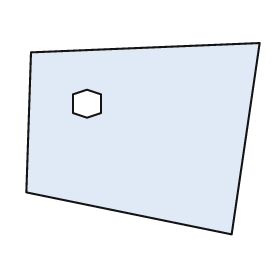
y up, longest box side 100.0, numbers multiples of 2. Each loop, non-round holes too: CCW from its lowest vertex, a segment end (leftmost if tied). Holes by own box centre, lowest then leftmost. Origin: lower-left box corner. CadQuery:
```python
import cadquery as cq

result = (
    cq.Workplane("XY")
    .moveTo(88.0, 0.0)
    .lineTo(100.0, 82.0)
    .lineTo(2.0, 78.0)
    .lineTo(0.0, 18.0)
    .close()
    .moveTo(26.0, 50.0)
    .lineTo(32.0, 52.0)
    .lineTo(32.0, 60.0)
    .lineTo(26.0, 62.0)
    .lineTo(20.0, 60.0)
    .lineTo(20.0, 52.0)
    .close()
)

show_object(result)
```